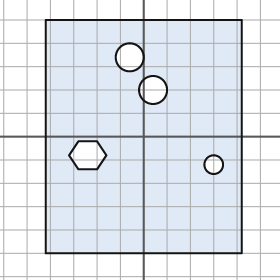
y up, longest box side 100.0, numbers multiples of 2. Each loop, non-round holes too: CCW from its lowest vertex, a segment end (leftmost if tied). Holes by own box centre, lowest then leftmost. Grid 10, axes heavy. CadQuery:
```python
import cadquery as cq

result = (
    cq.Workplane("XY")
    .moveTo(-42.0, -50.0)
    .lineTo(42.0, -50.0)
    .lineTo(42.0, 50.0)
    .lineTo(-42.0, 50.0)
    .close()
    .moveTo(30.0, -12.0)
    .circle(4.0)
    .moveTo(-28.0, -14.0)
    .lineTo(-20.0, -14.0)
    .lineTo(-16.0, -8.0)
    .lineTo(-20.0, -2.0)
    .lineTo(-28.0, -2.0)
    .lineTo(-32.0, -8.0)
    .close()
    .moveTo(4.0, 20.0)
    .circle(6.0)
    .moveTo(-6.0, 34.0)
    .circle(6.0)
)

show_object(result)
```